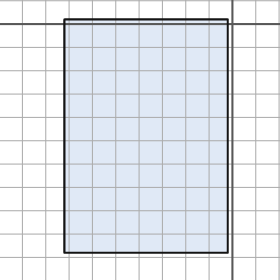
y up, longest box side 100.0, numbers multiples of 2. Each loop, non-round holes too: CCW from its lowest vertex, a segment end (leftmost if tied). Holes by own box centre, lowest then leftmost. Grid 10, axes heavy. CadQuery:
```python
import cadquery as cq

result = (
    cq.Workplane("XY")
    .moveTo(-72.0, -98.0)
    .lineTo(-2.0, -98.0)
    .lineTo(-2.0, 2.0)
    .lineTo(-72.0, 2.0)
    .close()
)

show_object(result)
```